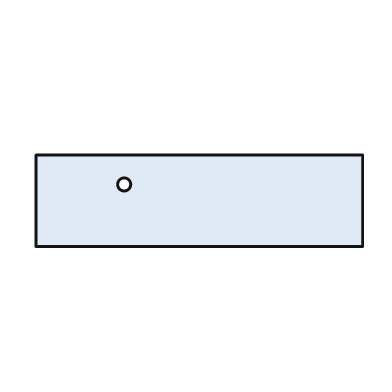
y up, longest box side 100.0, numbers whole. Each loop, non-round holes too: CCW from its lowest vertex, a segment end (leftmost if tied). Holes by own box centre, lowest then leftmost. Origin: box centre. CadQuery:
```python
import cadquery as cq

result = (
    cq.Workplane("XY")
    .moveTo(-50.0, -14.0)
    .lineTo(50.0, -14.0)
    .lineTo(50.0, 14.0)
    .lineTo(-50.0, 14.0)
    .close()
    .moveTo(-23.0, 5.0)
    .circle(2.0)
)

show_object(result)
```